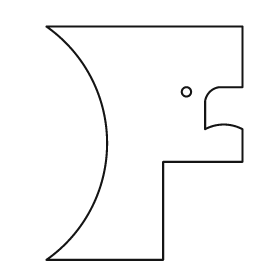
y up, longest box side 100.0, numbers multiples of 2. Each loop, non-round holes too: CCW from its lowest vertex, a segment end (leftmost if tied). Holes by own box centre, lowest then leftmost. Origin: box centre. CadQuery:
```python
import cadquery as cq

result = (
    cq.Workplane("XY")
    .moveTo(-42.0, -50.0)
    .lineTo(8.0, -50.0)
    .lineTo(8.0, -8.0)
    .lineTo(42.0, -8.0)
    .lineTo(42.0, 6.0)
    .threePointArc((34.0, 8.0), (26.0, 6.0))
    .lineTo(26.0, 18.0)
    .threePointArc((28.0, 22.0), (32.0, 24.0))
    .lineTo(42.0, 24.0)
    .lineTo(42.0, 50.0)
    .lineTo(-42.0, 50.0)
    .threePointArc((-16.0, 0.0), (-42.0, -50.0))
    .close()
    .moveTo(18.0, 22.0)
    .circle(2.0)
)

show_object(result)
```